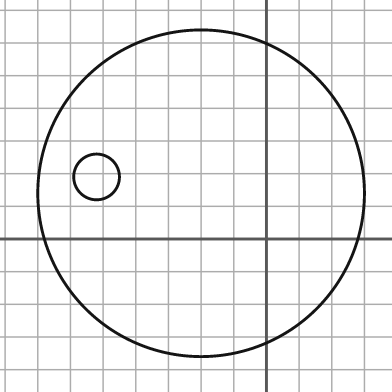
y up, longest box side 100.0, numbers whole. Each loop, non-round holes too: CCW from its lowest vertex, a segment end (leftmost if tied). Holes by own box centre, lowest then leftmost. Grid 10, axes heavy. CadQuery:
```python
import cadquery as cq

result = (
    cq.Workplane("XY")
    .moveTo(-20.0, 14.0)
    .circle(50.0)
    .moveTo(-52.0, 19.0)
    .circle(7.0)
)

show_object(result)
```